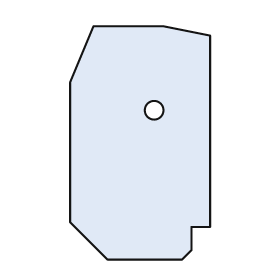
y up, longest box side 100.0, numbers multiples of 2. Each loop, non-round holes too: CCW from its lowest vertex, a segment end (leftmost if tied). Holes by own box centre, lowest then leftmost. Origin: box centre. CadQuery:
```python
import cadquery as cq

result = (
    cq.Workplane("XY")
    .moveTo(-14.0, -50.0)
    .lineTo(18.0, -50.0)
    .lineTo(22.0, -46.0)
    .lineTo(22.0, -36.0)
    .lineTo(30.0, -36.0)
    .lineTo(30.0, 46.0)
    .lineTo(10.0, 50.0)
    .lineTo(-20.0, 50.0)
    .lineTo(-30.0, 26.0)
    .lineTo(-30.0, -34.0)
    .close()
    .moveTo(6.0, 14.0)
    .circle(4.0)
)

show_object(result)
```